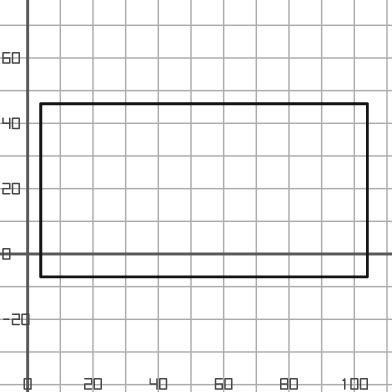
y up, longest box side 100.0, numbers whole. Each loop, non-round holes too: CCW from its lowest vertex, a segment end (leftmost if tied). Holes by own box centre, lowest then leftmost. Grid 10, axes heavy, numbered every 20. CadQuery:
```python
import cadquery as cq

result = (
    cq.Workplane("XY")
    .moveTo(4.0, -7.0)
    .lineTo(104.0, -7.0)
    .lineTo(104.0, 46.0)
    .lineTo(4.0, 46.0)
    .close()
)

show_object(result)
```